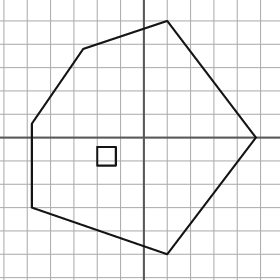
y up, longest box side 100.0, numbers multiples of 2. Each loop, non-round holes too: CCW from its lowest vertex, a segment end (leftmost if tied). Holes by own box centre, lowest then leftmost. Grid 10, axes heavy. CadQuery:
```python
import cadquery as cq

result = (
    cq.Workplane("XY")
    .moveTo(10.0, -50.0)
    .lineTo(48.0, 0.0)
    .lineTo(10.0, 50.0)
    .lineTo(-26.0, 38.0)
    .lineTo(-48.0, 6.0)
    .lineTo(-48.0, -30.0)
    .close()
    .moveTo(-20.0, -12.0)
    .lineTo(-12.0, -12.0)
    .lineTo(-12.0, -4.0)
    .lineTo(-20.0, -4.0)
    .close()
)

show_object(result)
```